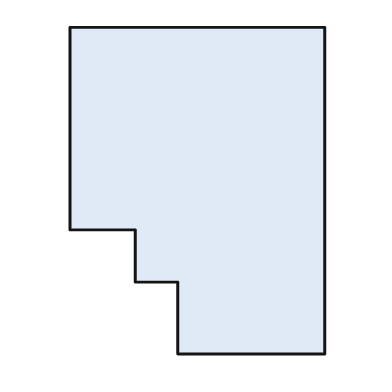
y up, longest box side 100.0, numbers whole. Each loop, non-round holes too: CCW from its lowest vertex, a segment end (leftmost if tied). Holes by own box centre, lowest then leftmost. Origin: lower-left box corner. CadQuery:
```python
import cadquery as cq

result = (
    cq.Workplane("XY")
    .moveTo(33.0, 0.0)
    .lineTo(78.0, 0.0)
    .lineTo(78.0, 100.0)
    .lineTo(0.0, 100.0)
    .lineTo(0.0, 38.0)
    .lineTo(20.0, 38.0)
    .lineTo(20.0, 22.0)
    .lineTo(33.0, 22.0)
    .close()
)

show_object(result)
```